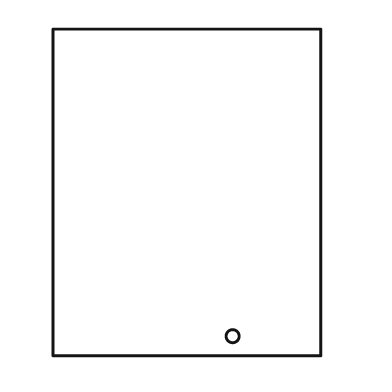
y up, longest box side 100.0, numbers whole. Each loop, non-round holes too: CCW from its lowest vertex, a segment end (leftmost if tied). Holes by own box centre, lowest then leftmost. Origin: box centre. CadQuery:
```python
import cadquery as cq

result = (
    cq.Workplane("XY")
    .moveTo(-41.0, -50.0)
    .lineTo(41.0, -50.0)
    .lineTo(41.0, 50.0)
    .lineTo(-41.0, 50.0)
    .close()
    .moveTo(14.0, -44.0)
    .circle(2.0)
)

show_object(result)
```